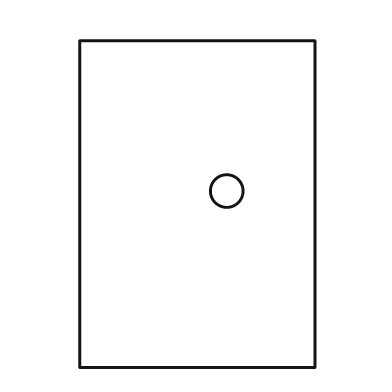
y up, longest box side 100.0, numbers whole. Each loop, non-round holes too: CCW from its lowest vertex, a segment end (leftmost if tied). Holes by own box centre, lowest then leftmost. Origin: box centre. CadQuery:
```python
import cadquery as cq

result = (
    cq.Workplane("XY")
    .moveTo(-36.0, -50.0)
    .lineTo(36.0, -50.0)
    .lineTo(36.0, 50.0)
    .lineTo(-36.0, 50.0)
    .close()
    .moveTo(9.0, 4.0)
    .circle(5.0)
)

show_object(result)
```